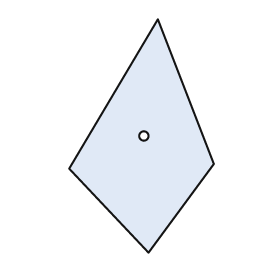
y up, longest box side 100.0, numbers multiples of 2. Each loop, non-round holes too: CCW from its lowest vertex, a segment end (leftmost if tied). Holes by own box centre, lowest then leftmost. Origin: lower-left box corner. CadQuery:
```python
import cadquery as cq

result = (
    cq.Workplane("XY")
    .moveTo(34.0, 0.0)
    .lineTo(62.0, 38.0)
    .lineTo(38.0, 100.0)
    .lineTo(0.0, 36.0)
    .close()
    .moveTo(32.0, 50.0)
    .circle(2.0)
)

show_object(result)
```